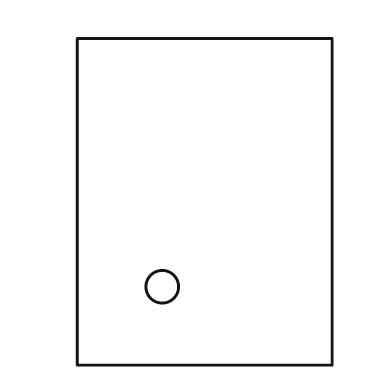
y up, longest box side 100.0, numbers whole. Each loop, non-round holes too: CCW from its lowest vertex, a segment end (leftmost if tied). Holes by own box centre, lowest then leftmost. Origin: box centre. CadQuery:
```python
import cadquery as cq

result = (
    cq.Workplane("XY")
    .moveTo(-39.0, -50.0)
    .lineTo(39.0, -50.0)
    .lineTo(39.0, 50.0)
    .lineTo(-39.0, 50.0)
    .close()
    .moveTo(-13.0, -26.0)
    .circle(5.0)
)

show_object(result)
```